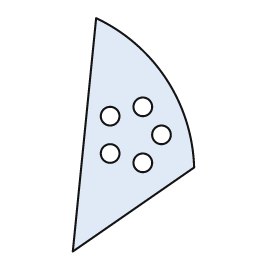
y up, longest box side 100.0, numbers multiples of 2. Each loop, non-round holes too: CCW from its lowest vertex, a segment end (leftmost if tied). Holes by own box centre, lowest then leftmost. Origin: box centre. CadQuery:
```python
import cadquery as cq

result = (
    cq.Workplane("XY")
    .moveTo(-26.0, -50.0)
    .lineTo(26.0, -14.0)
    .threePointArc((14.0, 24.0), (-16.0, 50.0))
    .close()
    .moveTo(4.0, -12.0)
    .circle(4.0)
    .moveTo(-10.0, -8.0)
    .circle(4.0)
    .moveTo(12.0, 0.0)
    .circle(4.0)
    .moveTo(-10.0, 8.0)
    .circle(4.0)
    .moveTo(4.0, 12.0)
    .circle(4.0)
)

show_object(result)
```